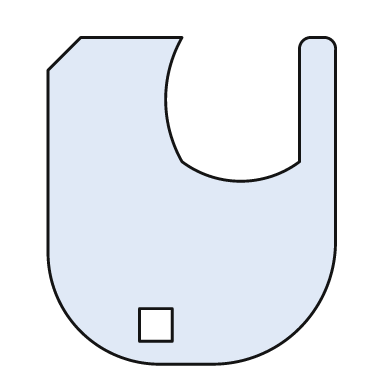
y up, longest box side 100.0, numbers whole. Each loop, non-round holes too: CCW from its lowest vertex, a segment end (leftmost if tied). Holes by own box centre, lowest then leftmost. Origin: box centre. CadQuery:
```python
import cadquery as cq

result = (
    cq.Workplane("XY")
    .moveTo(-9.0, -50.0)
    .lineTo(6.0, -50.0)
    .threePointArc((33.0, -39.0), (44.0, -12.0))
    .lineTo(44.0, 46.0)
    .threePointArc((43.0, 49.0), (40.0, 50.0))
    .lineTo(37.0, 50.0)
    .threePointArc((34.0, 49.0), (33.0, 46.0))
    .lineTo(33.0, 12.0)
    .threePointArc((15.0, 6.0), (-3.0, 12.0))
    .threePointArc((-8.0, 31.0), (-3.0, 50.0))
    .lineTo(-34.0, 50.0)
    .lineTo(-44.0, 40.0)
    .lineTo(-44.0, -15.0)
    .threePointArc((-34.0, -40.0), (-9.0, -50.0))
    .close()
    .moveTo(-16.0, -43.0)
    .lineTo(-6.0, -43.0)
    .lineTo(-6.0, -33.0)
    .lineTo(-16.0, -33.0)
    .close()
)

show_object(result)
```